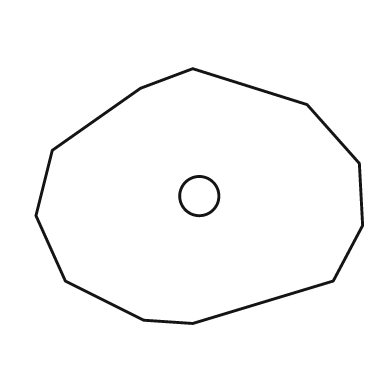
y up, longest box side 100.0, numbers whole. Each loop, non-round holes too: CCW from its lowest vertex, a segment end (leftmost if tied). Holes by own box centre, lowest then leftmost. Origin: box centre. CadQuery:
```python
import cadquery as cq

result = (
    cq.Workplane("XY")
    .moveTo(-2.0, -39.0)
    .lineTo(41.0, -26.0)
    .lineTo(50.0, -9.0)
    .lineTo(49.0, 10.0)
    .lineTo(33.0, 28.0)
    .lineTo(-2.0, 39.0)
    .lineTo(-18.0, 33.0)
    .lineTo(-45.0, 14.0)
    .lineTo(-50.0, -6.0)
    .lineTo(-41.0, -26.0)
    .lineTo(-17.0, -38.0)
    .close()
    .moveTo(0.0, 0.0)
    .circle(6.0)
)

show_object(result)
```